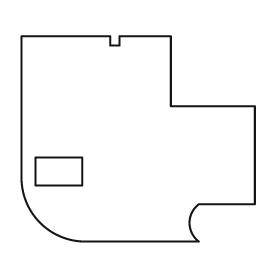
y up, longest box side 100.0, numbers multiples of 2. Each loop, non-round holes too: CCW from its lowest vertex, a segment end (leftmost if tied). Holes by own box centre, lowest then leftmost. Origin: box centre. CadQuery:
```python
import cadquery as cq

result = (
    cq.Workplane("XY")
    .moveTo(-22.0, -44.0)
    .lineTo(26.0, -44.0)
    .threePointArc((22.0, -36.0), (26.0, -28.0))
    .lineTo(50.0, -28.0)
    .lineTo(50.0, 14.0)
    .lineTo(14.0, 14.0)
    .lineTo(14.0, 44.0)
    .lineTo(-8.0, 44.0)
    .lineTo(-8.0, 40.0)
    .lineTo(-12.0, 40.0)
    .lineTo(-12.0, 44.0)
    .lineTo(-50.0, 44.0)
    .lineTo(-50.0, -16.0)
    .threePointArc((-42.0, -36.0), (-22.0, -44.0))
    .close()
    .moveTo(-44.0, -20.0)
    .lineTo(-24.0, -20.0)
    .lineTo(-24.0, -8.0)
    .lineTo(-44.0, -8.0)
    .close()
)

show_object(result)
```